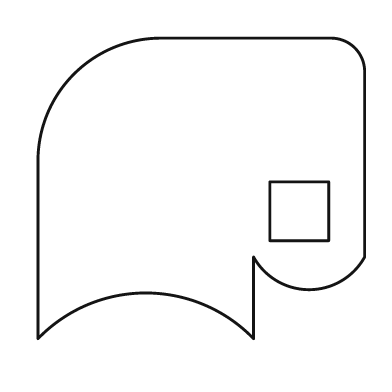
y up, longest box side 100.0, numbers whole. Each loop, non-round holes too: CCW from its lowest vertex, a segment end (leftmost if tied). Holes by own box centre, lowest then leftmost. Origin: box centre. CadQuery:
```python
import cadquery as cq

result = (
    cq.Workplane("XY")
    .moveTo(-50.0, -46.0)
    .threePointArc((-17.0, -32.0), (16.0, -46.0))
    .lineTo(16.0, -21.0)
    .threePointArc((33.0, -31.0), (50.0, -21.0))
    .lineTo(50.0, 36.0)
    .threePointArc((47.0, 43.0), (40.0, 46.0))
    .lineTo(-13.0, 46.0)
    .threePointArc((-39.0, 35.0), (-50.0, 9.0))
    .close()
    .moveTo(21.0, -16.0)
    .lineTo(39.0, -16.0)
    .lineTo(39.0, 2.0)
    .lineTo(21.0, 2.0)
    .close()
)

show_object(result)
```